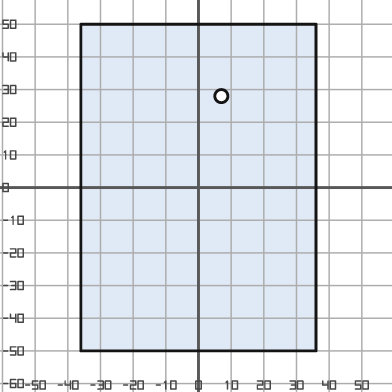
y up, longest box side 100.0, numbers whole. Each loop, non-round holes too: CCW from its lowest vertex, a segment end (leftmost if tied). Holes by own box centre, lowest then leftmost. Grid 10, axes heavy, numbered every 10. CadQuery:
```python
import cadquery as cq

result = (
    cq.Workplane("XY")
    .moveTo(-36.0, -50.0)
    .lineTo(36.0, -50.0)
    .lineTo(36.0, 50.0)
    .lineTo(-36.0, 50.0)
    .close()
    .moveTo(7.0, 28.0)
    .circle(2.0)
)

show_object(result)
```